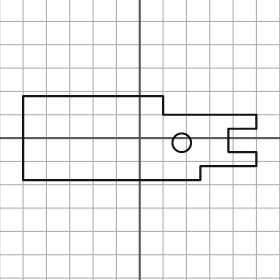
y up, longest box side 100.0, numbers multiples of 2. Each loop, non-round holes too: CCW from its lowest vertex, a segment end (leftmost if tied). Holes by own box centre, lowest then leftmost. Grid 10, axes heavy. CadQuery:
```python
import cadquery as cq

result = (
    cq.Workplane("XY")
    .moveTo(-50.0, -18.0)
    .lineTo(26.0, -18.0)
    .lineTo(26.0, -12.0)
    .lineTo(50.0, -12.0)
    .lineTo(50.0, -6.0)
    .lineTo(38.0, -6.0)
    .lineTo(38.0, 4.0)
    .lineTo(50.0, 4.0)
    .lineTo(50.0, 10.0)
    .lineTo(10.0, 10.0)
    .lineTo(10.0, 18.0)
    .lineTo(-50.0, 18.0)
    .close()
    .moveTo(18.0, -2.0)
    .circle(4.0)
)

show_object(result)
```